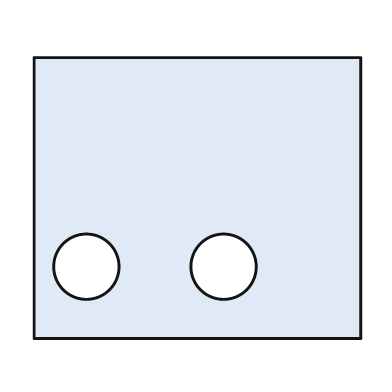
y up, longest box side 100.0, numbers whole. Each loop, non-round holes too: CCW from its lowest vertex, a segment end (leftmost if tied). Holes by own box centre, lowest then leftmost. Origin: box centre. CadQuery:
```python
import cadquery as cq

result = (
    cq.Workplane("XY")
    .moveTo(-50.0, -43.0)
    .lineTo(50.0, -43.0)
    .lineTo(50.0, 43.0)
    .lineTo(-50.0, 43.0)
    .close()
    .moveTo(-34.0, -21.0)
    .circle(10.0)
    .moveTo(8.0, -21.0)
    .circle(10.0)
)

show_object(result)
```